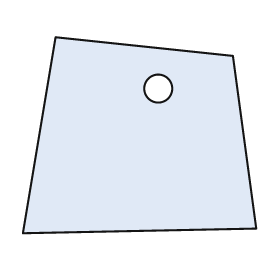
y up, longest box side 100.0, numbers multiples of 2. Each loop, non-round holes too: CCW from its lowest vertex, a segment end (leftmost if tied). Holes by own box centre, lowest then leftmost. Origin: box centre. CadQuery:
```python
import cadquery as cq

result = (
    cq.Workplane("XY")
    .moveTo(-50.0, -42.0)
    .lineTo(50.0, -40.0)
    .lineTo(40.0, 34.0)
    .lineTo(-36.0, 42.0)
    .close()
    .moveTo(8.0, 20.0)
    .circle(6.0)
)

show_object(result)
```